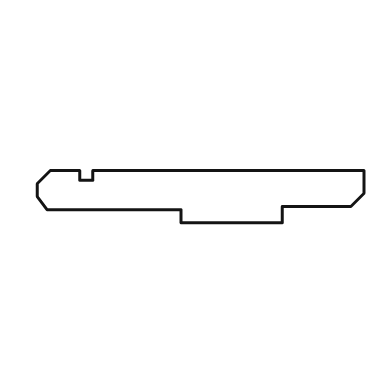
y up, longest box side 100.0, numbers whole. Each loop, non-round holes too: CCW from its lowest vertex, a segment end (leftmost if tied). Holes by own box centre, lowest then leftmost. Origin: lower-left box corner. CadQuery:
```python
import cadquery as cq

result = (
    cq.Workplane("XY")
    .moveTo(44.0, 0.0)
    .lineTo(75.0, 0.0)
    .lineTo(75.0, 5.0)
    .lineTo(96.0, 5.0)
    .lineTo(100.0, 9.0)
    .lineTo(100.0, 16.0)
    .lineTo(17.0, 16.0)
    .lineTo(17.0, 13.0)
    .lineTo(13.0, 13.0)
    .lineTo(13.0, 16.0)
    .lineTo(4.0, 16.0)
    .lineTo(0.0, 12.0)
    .lineTo(0.0, 8.0)
    .lineTo(3.0, 4.0)
    .lineTo(44.0, 4.0)
    .close()
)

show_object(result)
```